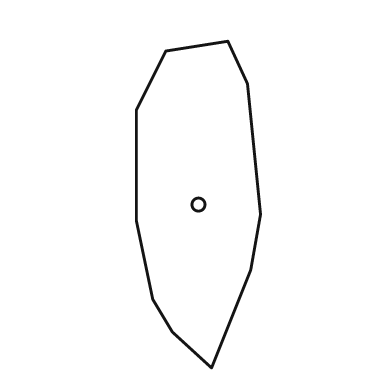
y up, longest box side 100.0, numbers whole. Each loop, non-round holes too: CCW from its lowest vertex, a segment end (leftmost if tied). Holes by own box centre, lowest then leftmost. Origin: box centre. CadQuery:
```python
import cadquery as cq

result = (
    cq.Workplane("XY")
    .moveTo(4.0, -50.0)
    .lineTo(16.0, -20.0)
    .lineTo(19.0, -3.0)
    .lineTo(15.0, 37.0)
    .lineTo(9.0, 50.0)
    .lineTo(-10.0, 47.0)
    .lineTo(-19.0, 29.0)
    .lineTo(-19.0, -5.0)
    .lineTo(-14.0, -29.0)
    .lineTo(-8.0, -39.0)
    .close()
    .moveTo(0.0, 0.0)
    .circle(2.0)
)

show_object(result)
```